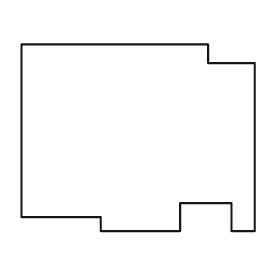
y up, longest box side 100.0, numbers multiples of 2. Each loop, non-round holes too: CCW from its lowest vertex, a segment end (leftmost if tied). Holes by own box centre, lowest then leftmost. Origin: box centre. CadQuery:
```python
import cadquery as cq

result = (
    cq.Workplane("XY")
    .moveTo(-16.0, -40.0)
    .lineTo(18.0, -40.0)
    .lineTo(18.0, -28.0)
    .lineTo(40.0, -28.0)
    .lineTo(40.0, -40.0)
    .lineTo(50.0, -40.0)
    .lineTo(50.0, 32.0)
    .lineTo(30.0, 32.0)
    .lineTo(30.0, 40.0)
    .lineTo(-50.0, 40.0)
    .lineTo(-50.0, -34.0)
    .lineTo(-16.0, -34.0)
    .close()
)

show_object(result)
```